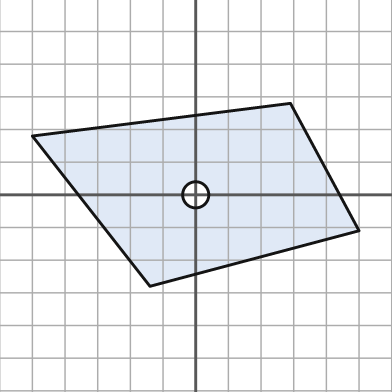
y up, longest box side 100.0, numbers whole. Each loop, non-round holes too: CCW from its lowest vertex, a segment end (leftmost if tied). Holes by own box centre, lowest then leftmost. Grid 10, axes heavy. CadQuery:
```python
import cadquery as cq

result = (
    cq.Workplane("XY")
    .moveTo(-14.0, -28.0)
    .lineTo(50.0, -11.0)
    .lineTo(29.0, 28.0)
    .lineTo(-50.0, 18.0)
    .close()
    .moveTo(0.0, 0.0)
    .circle(4.0)
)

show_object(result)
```